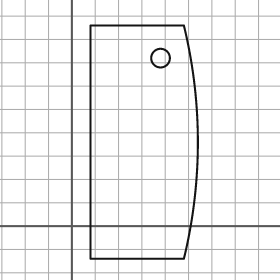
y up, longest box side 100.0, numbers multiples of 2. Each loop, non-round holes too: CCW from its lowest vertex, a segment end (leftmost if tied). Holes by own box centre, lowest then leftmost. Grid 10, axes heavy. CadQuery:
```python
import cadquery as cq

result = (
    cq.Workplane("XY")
    .moveTo(8.0, -14.0)
    .lineTo(48.0, -14.0)
    .threePointArc((54.0, 36.0), (48.0, 86.0))
    .lineTo(8.0, 86.0)
    .close()
    .moveTo(38.0, 72.0)
    .circle(4.0)
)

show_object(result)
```